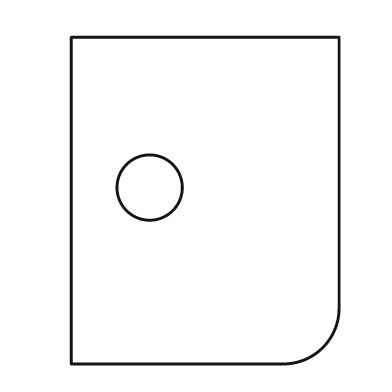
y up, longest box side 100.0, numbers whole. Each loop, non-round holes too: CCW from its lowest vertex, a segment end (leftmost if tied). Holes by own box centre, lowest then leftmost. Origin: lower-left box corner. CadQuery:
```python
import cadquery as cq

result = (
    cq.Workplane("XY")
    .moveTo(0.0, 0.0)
    .lineTo(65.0, 0.0)
    .threePointArc((77.0, 5.0), (82.0, 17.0))
    .lineTo(82.0, 100.0)
    .lineTo(0.0, 100.0)
    .close()
    .moveTo(24.0, 54.0)
    .circle(10.0)
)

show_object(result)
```